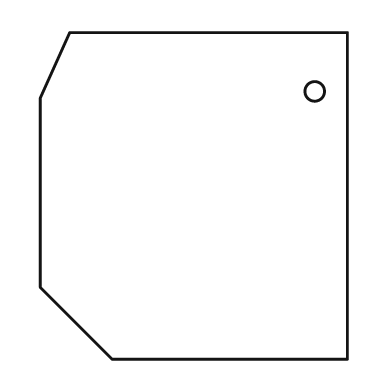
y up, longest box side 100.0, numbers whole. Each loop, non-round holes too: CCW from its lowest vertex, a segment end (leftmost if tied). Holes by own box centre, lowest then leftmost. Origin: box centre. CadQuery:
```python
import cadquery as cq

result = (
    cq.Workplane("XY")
    .moveTo(-25.0, -50.0)
    .lineTo(47.0, -50.0)
    .lineTo(47.0, 50.0)
    .lineTo(-38.0, 50.0)
    .lineTo(-47.0, 30.0)
    .lineTo(-47.0, -28.0)
    .close()
    .moveTo(37.0, 32.0)
    .circle(3.0)
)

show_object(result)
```